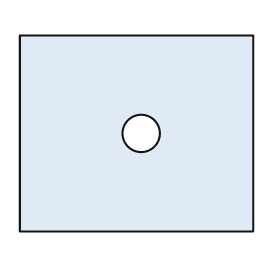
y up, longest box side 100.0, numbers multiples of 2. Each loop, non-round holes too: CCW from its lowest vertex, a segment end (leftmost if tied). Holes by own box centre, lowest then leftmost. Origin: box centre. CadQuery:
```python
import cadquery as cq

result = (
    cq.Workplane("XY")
    .moveTo(-50.0, -42.0)
    .lineTo(50.0, -42.0)
    .lineTo(50.0, 42.0)
    .lineTo(-50.0, 42.0)
    .close()
    .moveTo(2.0, 0.0)
    .circle(8.0)
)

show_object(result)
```